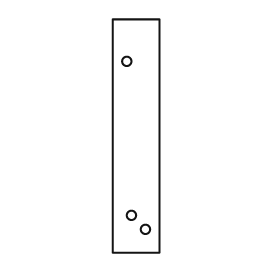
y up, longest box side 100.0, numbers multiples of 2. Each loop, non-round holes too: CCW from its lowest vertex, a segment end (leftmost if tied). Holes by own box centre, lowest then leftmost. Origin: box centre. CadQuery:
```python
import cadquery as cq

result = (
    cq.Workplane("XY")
    .moveTo(-10.0, -50.0)
    .lineTo(10.0, -50.0)
    .lineTo(10.0, 50.0)
    .lineTo(-10.0, 50.0)
    .close()
    .moveTo(4.0, -40.0)
    .circle(2.0)
    .moveTo(-2.0, -34.0)
    .circle(2.0)
    .moveTo(-4.0, 32.0)
    .circle(2.0)
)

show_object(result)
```